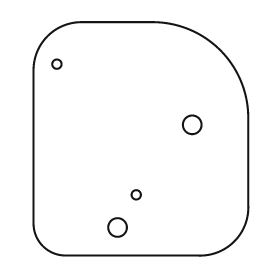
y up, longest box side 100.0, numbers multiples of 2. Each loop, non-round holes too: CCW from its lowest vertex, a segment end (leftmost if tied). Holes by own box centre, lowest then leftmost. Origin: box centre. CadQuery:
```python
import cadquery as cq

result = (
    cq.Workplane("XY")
    .moveTo(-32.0, -50.0)
    .lineTo(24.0, -50.0)
    .threePointArc((40.0, -44.0), (46.0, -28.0))
    .lineTo(46.0, 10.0)
    .threePointArc((34.0, 38.0), (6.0, 50.0))
    .lineTo(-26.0, 50.0)
    .threePointArc((-40.0, 44.0), (-46.0, 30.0))
    .lineTo(-46.0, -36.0)
    .threePointArc((-42.0, -46.0), (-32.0, -50.0))
    .close()
    .moveTo(-10.0, -38.0)
    .circle(4.0)
    .moveTo(-2.0, -24.0)
    .circle(2.0)
    .moveTo(22.0, 6.0)
    .circle(4.0)
    .moveTo(-36.0, 32.0)
    .circle(2.0)
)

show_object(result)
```